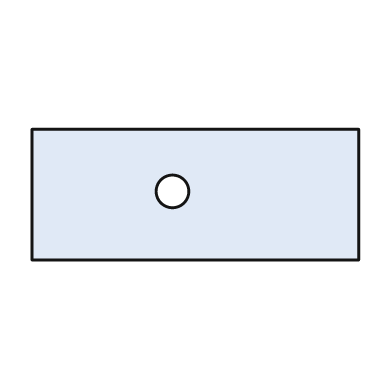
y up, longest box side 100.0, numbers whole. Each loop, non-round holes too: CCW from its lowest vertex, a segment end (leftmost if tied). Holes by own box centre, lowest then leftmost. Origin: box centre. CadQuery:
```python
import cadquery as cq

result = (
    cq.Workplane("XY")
    .moveTo(-50.0, -20.0)
    .lineTo(50.0, -20.0)
    .lineTo(50.0, 20.0)
    .lineTo(-50.0, 20.0)
    .close()
    .moveTo(-7.0, 1.0)
    .circle(5.0)
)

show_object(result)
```